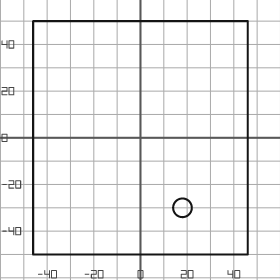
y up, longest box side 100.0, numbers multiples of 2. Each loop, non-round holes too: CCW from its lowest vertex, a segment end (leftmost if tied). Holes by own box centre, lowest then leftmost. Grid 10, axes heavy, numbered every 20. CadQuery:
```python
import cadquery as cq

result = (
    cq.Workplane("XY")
    .moveTo(-46.0, -50.0)
    .lineTo(46.0, -50.0)
    .lineTo(46.0, 50.0)
    .lineTo(-46.0, 50.0)
    .close()
    .moveTo(18.0, -30.0)
    .circle(4.0)
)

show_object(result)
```